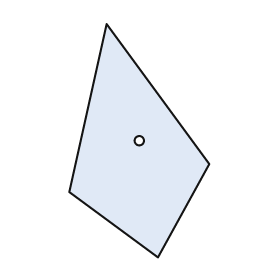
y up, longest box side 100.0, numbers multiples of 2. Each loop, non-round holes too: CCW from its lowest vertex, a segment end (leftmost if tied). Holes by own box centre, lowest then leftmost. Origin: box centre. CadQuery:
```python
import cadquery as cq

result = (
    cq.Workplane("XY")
    .moveTo(8.0, -50.0)
    .lineTo(30.0, -10.0)
    .lineTo(-14.0, 50.0)
    .lineTo(-30.0, -22.0)
    .close()
    .moveTo(0.0, 0.0)
    .circle(2.0)
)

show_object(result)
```